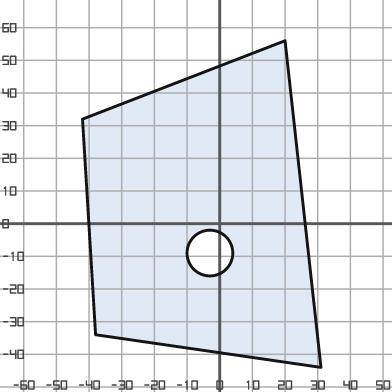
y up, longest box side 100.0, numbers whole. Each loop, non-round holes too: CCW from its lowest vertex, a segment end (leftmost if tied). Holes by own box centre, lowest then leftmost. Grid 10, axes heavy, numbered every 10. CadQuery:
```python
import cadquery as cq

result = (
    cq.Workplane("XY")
    .moveTo(31.0, -44.0)
    .lineTo(20.0, 56.0)
    .lineTo(-42.0, 32.0)
    .lineTo(-38.0, -34.0)
    .close()
    .moveTo(-3.0, -9.0)
    .circle(7.0)
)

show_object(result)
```